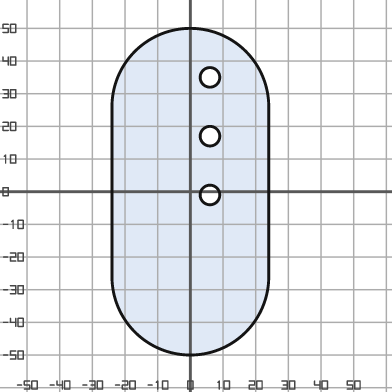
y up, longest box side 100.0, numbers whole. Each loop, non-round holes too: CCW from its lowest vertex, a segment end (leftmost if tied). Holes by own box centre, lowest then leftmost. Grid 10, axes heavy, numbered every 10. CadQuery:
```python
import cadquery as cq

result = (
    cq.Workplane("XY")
    .moveTo(-24.0, -26.0)
    .threePointArc((0.0, -50.0), (24.0, -26.0))
    .lineTo(24.0, 26.0)
    .threePointArc((0.0, 50.0), (-24.0, 26.0))
    .close()
    .moveTo(6.0, -1.0)
    .circle(3.0)
    .moveTo(6.0, 17.0)
    .circle(3.0)
    .moveTo(6.0, 35.0)
    .circle(3.0)
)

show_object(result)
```